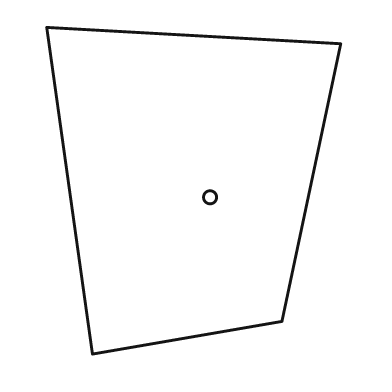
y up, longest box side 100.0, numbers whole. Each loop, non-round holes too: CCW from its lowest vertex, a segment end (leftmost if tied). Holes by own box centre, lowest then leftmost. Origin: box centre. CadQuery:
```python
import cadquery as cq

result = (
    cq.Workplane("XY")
    .moveTo(-31.0, -50.0)
    .lineTo(27.0, -40.0)
    .lineTo(45.0, 45.0)
    .lineTo(-45.0, 50.0)
    .close()
    .moveTo(5.0, -2.0)
    .circle(2.0)
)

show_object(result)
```